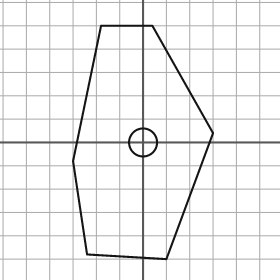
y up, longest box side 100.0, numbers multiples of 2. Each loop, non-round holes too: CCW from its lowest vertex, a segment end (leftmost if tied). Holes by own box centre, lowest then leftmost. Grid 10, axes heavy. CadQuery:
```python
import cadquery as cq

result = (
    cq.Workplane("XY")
    .moveTo(10.0, -50.0)
    .lineTo(30.0, 4.0)
    .lineTo(4.0, 50.0)
    .lineTo(-18.0, 50.0)
    .lineTo(-30.0, -8.0)
    .lineTo(-24.0, -48.0)
    .close()
    .moveTo(0.0, 0.0)
    .circle(6.0)
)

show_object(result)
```